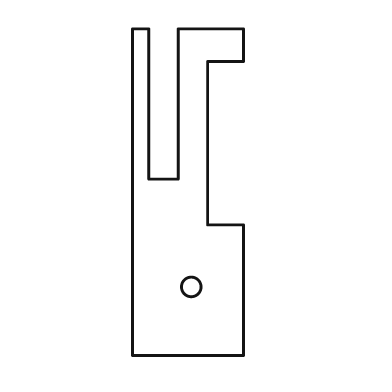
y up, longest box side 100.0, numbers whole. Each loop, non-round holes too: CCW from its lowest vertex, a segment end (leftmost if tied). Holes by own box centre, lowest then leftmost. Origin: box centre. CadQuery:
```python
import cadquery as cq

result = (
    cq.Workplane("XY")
    .moveTo(-17.0, -50.0)
    .lineTo(17.0, -50.0)
    .lineTo(17.0, -10.0)
    .lineTo(6.0, -10.0)
    .lineTo(6.0, 40.0)
    .lineTo(17.0, 40.0)
    .lineTo(17.0, 50.0)
    .lineTo(-3.0, 50.0)
    .lineTo(-3.0, 4.0)
    .lineTo(-12.0, 4.0)
    .lineTo(-12.0, 50.0)
    .lineTo(-17.0, 50.0)
    .close()
    .moveTo(1.0, -29.0)
    .circle(3.0)
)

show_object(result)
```